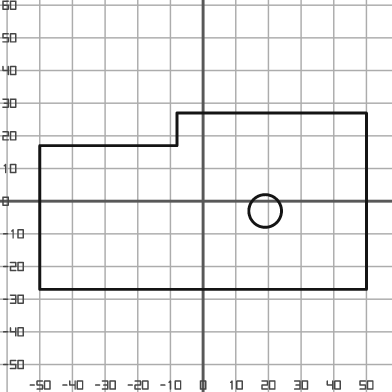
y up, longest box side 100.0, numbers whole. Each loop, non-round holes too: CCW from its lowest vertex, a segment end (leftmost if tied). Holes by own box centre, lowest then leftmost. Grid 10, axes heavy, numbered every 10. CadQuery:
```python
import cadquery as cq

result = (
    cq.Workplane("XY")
    .moveTo(-50.0, -27.0)
    .lineTo(50.0, -27.0)
    .lineTo(50.0, 27.0)
    .lineTo(-8.0, 27.0)
    .lineTo(-8.0, 17.0)
    .lineTo(-50.0, 17.0)
    .close()
    .moveTo(19.0, -3.0)
    .circle(5.0)
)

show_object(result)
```